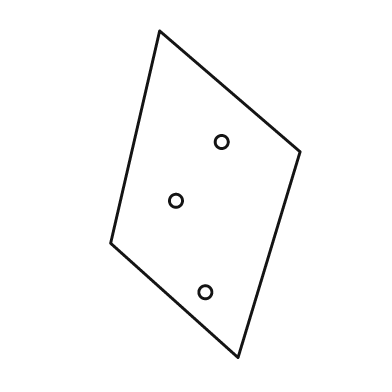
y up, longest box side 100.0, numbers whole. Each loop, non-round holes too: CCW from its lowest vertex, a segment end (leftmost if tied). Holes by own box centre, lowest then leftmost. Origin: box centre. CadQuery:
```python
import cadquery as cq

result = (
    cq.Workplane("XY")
    .moveTo(10.0, -50.0)
    .lineTo(29.0, 13.0)
    .lineTo(-14.0, 50.0)
    .lineTo(-29.0, -15.0)
    .close()
    .moveTo(0.0, -30.0)
    .circle(2.0)
    .moveTo(-9.0, -2.0)
    .circle(2.0)
    .moveTo(5.0, 16.0)
    .circle(2.0)
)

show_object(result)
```